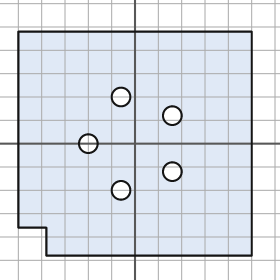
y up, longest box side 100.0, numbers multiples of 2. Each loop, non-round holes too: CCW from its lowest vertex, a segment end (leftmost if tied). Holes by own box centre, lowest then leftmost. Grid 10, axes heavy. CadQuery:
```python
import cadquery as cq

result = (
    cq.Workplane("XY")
    .moveTo(-38.0, -48.0)
    .lineTo(50.0, -48.0)
    .lineTo(50.0, 48.0)
    .lineTo(-50.0, 48.0)
    .lineTo(-50.0, -36.0)
    .lineTo(-38.0, -36.0)
    .close()
    .moveTo(-6.0, -20.0)
    .circle(4.0)
    .moveTo(16.0, -12.0)
    .circle(4.0)
    .moveTo(-20.0, 0.0)
    .circle(4.0)
    .moveTo(16.0, 12.0)
    .circle(4.0)
    .moveTo(-6.0, 20.0)
    .circle(4.0)
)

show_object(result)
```